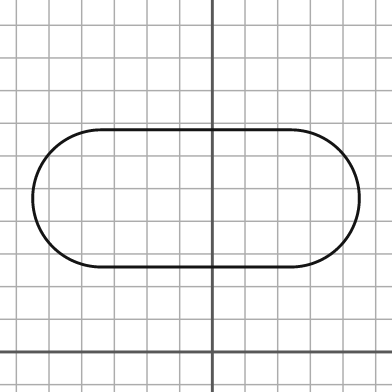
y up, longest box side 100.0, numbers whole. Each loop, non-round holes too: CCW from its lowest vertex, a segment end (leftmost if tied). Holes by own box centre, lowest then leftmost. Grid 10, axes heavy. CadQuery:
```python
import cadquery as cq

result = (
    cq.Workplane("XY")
    .moveTo(-34.0, 26.0)
    .lineTo(24.0, 26.0)
    .threePointArc((45.0, 47.0), (24.0, 68.0))
    .lineTo(-34.0, 68.0)
    .threePointArc((-55.0, 47.0), (-34.0, 26.0))
    .close()
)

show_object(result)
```